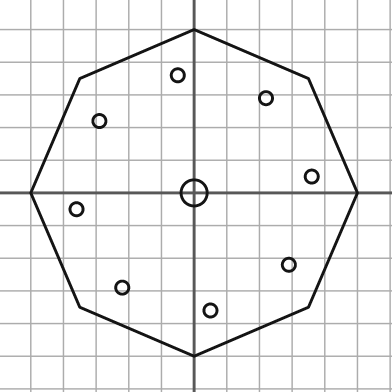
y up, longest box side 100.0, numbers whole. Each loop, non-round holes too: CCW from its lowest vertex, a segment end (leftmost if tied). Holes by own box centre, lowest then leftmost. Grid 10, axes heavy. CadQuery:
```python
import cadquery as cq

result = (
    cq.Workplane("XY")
    .moveTo(0.0, -50.0)
    .lineTo(35.0, -35.0)
    .lineTo(50.0, 0.0)
    .lineTo(35.0, 35.0)
    .lineTo(0.0, 50.0)
    .lineTo(-35.0, 35.0)
    .lineTo(-50.0, 0.0)
    .lineTo(-35.0, -35.0)
    .close()
    .moveTo(5.0, -36.0)
    .circle(2.0)
    .moveTo(-22.0, -29.0)
    .circle(2.0)
    .moveTo(29.0, -22.0)
    .circle(2.0)
    .moveTo(-36.0, -5.0)
    .circle(2.0)
    .moveTo(0.0, 0.0)
    .circle(4.0)
    .moveTo(36.0, 5.0)
    .circle(2.0)
    .moveTo(-29.0, 22.0)
    .circle(2.0)
    .moveTo(22.0, 29.0)
    .circle(2.0)
    .moveTo(-5.0, 36.0)
    .circle(2.0)
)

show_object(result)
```